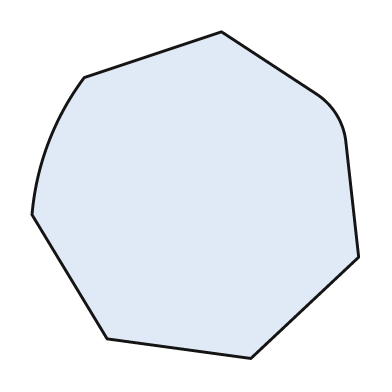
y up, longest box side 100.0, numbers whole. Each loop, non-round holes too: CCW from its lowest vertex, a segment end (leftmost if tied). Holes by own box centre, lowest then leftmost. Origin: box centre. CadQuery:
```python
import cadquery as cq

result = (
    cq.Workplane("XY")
    .moveTo(17.0, -50.0)
    .lineTo(50.0, -19.0)
    .lineTo(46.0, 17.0)
    .threePointArc((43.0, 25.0), (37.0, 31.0))
    .lineTo(8.0, 50.0)
    .lineTo(-34.0, 36.0)
    .threePointArc((-45.0, 16.0), (-50.0, -6.0))
    .lineTo(-27.0, -44.0)
    .close()
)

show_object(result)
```